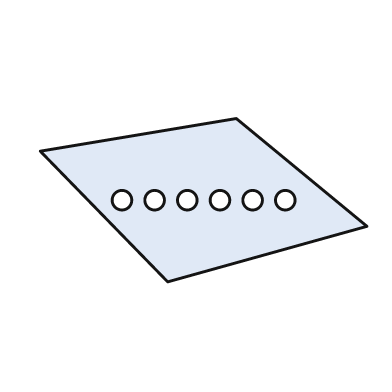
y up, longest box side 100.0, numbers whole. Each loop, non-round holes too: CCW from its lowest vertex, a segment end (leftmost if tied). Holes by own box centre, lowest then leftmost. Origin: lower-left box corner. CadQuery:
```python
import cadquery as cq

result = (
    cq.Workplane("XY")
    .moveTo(39.0, 0.0)
    .lineTo(100.0, 17.0)
    .lineTo(60.0, 50.0)
    .lineTo(0.0, 40.0)
    .close()
    .moveTo(25.0, 25.0)
    .circle(3.0)
    .moveTo(35.0, 25.0)
    .circle(3.0)
    .moveTo(45.0, 25.0)
    .circle(3.0)
    .moveTo(55.0, 25.0)
    .circle(3.0)
    .moveTo(65.0, 25.0)
    .circle(3.0)
    .moveTo(75.0, 25.0)
    .circle(3.0)
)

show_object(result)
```